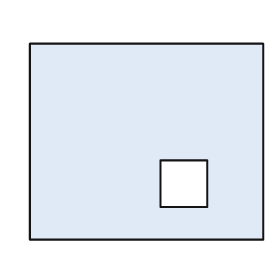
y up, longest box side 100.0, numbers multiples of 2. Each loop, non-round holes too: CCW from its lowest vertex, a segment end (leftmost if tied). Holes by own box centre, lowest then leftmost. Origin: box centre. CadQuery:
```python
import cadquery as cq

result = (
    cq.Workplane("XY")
    .moveTo(-50.0, -42.0)
    .lineTo(50.0, -42.0)
    .lineTo(50.0, 42.0)
    .lineTo(-50.0, 42.0)
    .close()
    .moveTo(6.0, -28.0)
    .lineTo(26.0, -28.0)
    .lineTo(26.0, -8.0)
    .lineTo(6.0, -8.0)
    .close()
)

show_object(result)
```